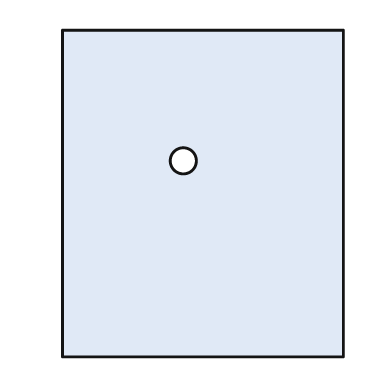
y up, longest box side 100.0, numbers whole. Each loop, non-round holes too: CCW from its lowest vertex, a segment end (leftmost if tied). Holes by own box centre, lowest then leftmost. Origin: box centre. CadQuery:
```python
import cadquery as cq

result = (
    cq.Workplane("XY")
    .moveTo(-43.0, -50.0)
    .lineTo(43.0, -50.0)
    .lineTo(43.0, 50.0)
    .lineTo(-43.0, 50.0)
    .close()
    .moveTo(-6.0, 10.0)
    .circle(4.0)
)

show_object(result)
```